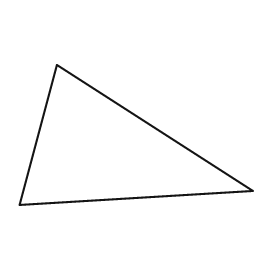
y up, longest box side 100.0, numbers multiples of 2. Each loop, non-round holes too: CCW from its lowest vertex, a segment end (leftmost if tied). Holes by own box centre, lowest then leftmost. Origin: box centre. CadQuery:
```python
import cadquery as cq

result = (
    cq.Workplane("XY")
    .moveTo(-50.0, -30.0)
    .lineTo(50.0, -24.0)
    .lineTo(-34.0, 30.0)
    .close()
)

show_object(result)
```